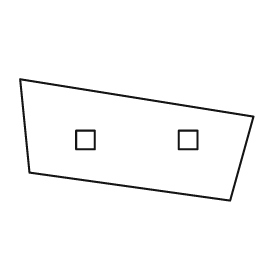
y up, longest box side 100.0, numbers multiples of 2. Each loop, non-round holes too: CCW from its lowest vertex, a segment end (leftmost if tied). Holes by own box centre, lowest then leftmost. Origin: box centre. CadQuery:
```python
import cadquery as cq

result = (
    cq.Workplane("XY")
    .moveTo(40.0, -26.0)
    .lineTo(50.0, 10.0)
    .lineTo(-50.0, 26.0)
    .lineTo(-46.0, -14.0)
    .close()
    .moveTo(-26.0, -4.0)
    .lineTo(-18.0, -4.0)
    .lineTo(-18.0, 4.0)
    .lineTo(-26.0, 4.0)
    .close()
    .moveTo(18.0, -4.0)
    .lineTo(26.0, -4.0)
    .lineTo(26.0, 4.0)
    .lineTo(18.0, 4.0)
    .close()
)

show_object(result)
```